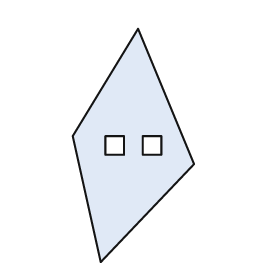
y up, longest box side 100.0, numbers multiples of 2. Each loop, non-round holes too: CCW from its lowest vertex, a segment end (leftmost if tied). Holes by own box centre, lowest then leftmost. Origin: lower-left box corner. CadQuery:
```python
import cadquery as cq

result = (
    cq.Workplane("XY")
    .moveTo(12.0, 0.0)
    .lineTo(52.0, 42.0)
    .lineTo(28.0, 100.0)
    .lineTo(0.0, 54.0)
    .close()
    .moveTo(14.0, 46.0)
    .lineTo(22.0, 46.0)
    .lineTo(22.0, 54.0)
    .lineTo(14.0, 54.0)
    .close()
    .moveTo(30.0, 46.0)
    .lineTo(38.0, 46.0)
    .lineTo(38.0, 54.0)
    .lineTo(30.0, 54.0)
    .close()
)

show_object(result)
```